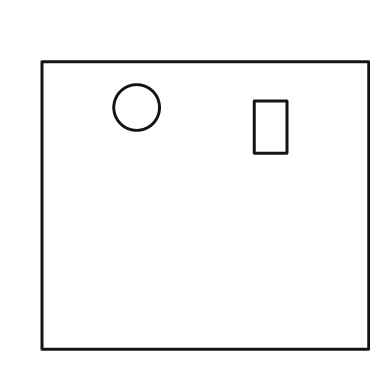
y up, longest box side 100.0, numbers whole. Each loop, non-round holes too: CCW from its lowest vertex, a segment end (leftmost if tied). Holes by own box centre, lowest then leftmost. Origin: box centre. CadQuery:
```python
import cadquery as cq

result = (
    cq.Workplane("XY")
    .moveTo(-50.0, -44.0)
    .lineTo(50.0, -44.0)
    .lineTo(50.0, 44.0)
    .lineTo(-50.0, 44.0)
    .close()
    .moveTo(15.0, 16.0)
    .lineTo(25.0, 16.0)
    .lineTo(25.0, 32.0)
    .lineTo(15.0, 32.0)
    .close()
    .moveTo(-21.0, 30.0)
    .circle(7.0)
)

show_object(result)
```